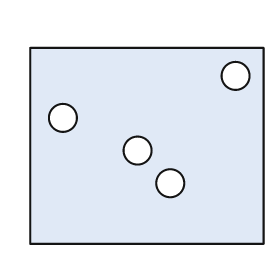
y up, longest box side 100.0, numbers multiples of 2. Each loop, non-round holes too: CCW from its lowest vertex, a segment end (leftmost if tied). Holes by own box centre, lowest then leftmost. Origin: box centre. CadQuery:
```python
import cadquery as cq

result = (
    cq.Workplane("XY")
    .moveTo(-50.0, -42.0)
    .lineTo(50.0, -42.0)
    .lineTo(50.0, 42.0)
    .lineTo(-50.0, 42.0)
    .close()
    .moveTo(10.0, -16.0)
    .circle(6.0)
    .moveTo(-4.0, -2.0)
    .circle(6.0)
    .moveTo(-36.0, 12.0)
    .circle(6.0)
    .moveTo(38.0, 30.0)
    .circle(6.0)
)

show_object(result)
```